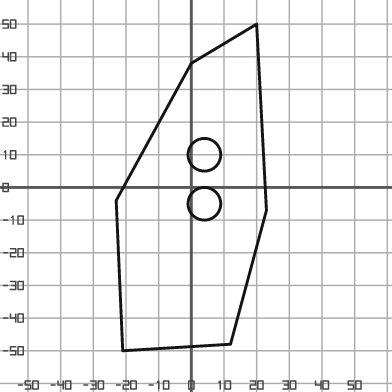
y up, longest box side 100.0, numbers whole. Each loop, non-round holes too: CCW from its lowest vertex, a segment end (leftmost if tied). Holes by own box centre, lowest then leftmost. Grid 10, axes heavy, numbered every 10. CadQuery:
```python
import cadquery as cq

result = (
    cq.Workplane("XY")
    .moveTo(-21.0, -50.0)
    .lineTo(12.0, -48.0)
    .lineTo(23.0, -7.0)
    .lineTo(20.0, 50.0)
    .lineTo(0.0, 38.0)
    .lineTo(-23.0, -4.0)
    .close()
    .moveTo(4.0, -5.0)
    .circle(5.0)
    .moveTo(4.0, 10.0)
    .circle(5.0)
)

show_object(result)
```